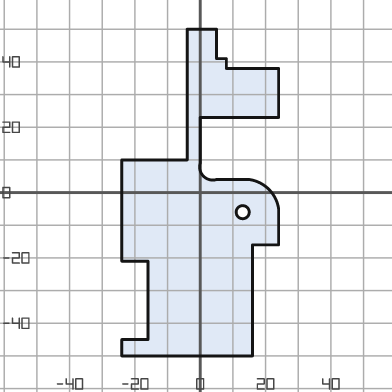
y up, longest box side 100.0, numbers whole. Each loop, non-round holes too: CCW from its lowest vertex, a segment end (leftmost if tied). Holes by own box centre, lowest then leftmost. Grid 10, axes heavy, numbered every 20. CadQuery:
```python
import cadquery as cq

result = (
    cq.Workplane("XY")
    .moveTo(-24.0, -50.0)
    .lineTo(16.0, -50.0)
    .lineTo(16.0, -16.0)
    .lineTo(24.0, -16.0)
    .lineTo(24.0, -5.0)
    .threePointArc((21.0, 1.0), (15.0, 4.0))
    .lineTo(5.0, 4.0)
    .threePointArc((1.0, 5.0), (0.0, 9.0))
    .lineTo(0.0, 23.0)
    .lineTo(24.0, 23.0)
    .lineTo(24.0, 38.0)
    .lineTo(8.0, 38.0)
    .lineTo(8.0, 41.0)
    .lineTo(5.0, 41.0)
    .lineTo(5.0, 50.0)
    .lineTo(-4.0, 50.0)
    .lineTo(-4.0, 10.0)
    .lineTo(-24.0, 10.0)
    .lineTo(-24.0, -21.0)
    .lineTo(-16.0, -21.0)
    .lineTo(-16.0, -45.0)
    .lineTo(-24.0, -45.0)
    .close()
    .moveTo(13.0, -6.0)
    .circle(2.0)
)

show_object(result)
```